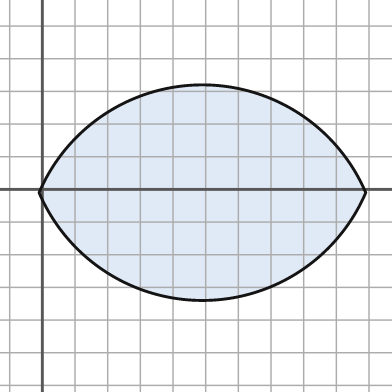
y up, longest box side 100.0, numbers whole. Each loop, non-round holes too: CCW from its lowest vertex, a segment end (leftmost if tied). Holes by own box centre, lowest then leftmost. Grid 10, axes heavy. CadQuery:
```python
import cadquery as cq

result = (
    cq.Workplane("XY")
    .moveTo(-1.0, -1.0)
    .threePointArc((49.0, -34.0), (99.0, -1.0))
    .threePointArc((49.0, 32.0), (-1.0, -1.0))
    .close()
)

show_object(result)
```